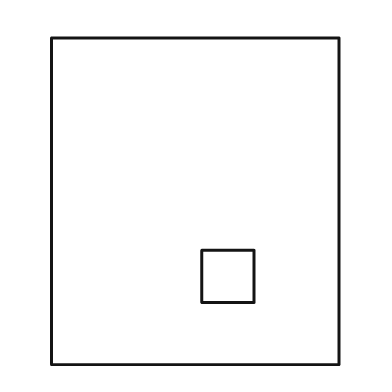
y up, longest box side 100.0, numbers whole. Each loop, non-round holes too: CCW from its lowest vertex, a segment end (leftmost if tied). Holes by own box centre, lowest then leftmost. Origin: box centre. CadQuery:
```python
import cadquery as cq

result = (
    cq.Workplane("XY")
    .moveTo(-44.0, -50.0)
    .lineTo(44.0, -50.0)
    .lineTo(44.0, 50.0)
    .lineTo(-44.0, 50.0)
    .close()
    .moveTo(2.0, -31.0)
    .lineTo(18.0, -31.0)
    .lineTo(18.0, -15.0)
    .lineTo(2.0, -15.0)
    .close()
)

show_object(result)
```